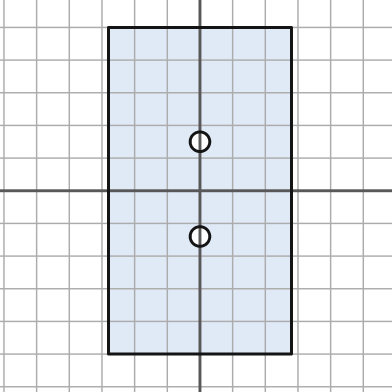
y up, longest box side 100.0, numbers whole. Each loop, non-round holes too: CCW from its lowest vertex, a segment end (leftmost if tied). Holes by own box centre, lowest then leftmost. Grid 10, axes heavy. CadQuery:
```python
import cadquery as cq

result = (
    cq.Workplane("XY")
    .moveTo(-28.0, -50.0)
    .lineTo(28.0, -50.0)
    .lineTo(28.0, 50.0)
    .lineTo(-28.0, 50.0)
    .close()
    .moveTo(0.0, -14.0)
    .circle(3.0)
    .moveTo(0.0, 15.0)
    .circle(3.0)
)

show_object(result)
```